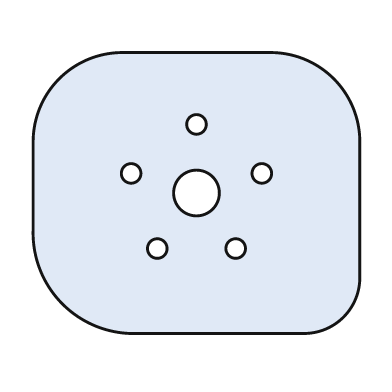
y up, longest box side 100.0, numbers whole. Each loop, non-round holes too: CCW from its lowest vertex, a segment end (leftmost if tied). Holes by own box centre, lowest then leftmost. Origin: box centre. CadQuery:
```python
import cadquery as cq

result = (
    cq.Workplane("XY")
    .moveTo(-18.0, -43.0)
    .lineTo(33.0, -43.0)
    .threePointArc((45.0, -38.0), (50.0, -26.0))
    .lineTo(50.0, 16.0)
    .threePointArc((42.0, 35.0), (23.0, 43.0))
    .lineTo(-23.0, 43.0)
    .threePointArc((-42.0, 35.0), (-50.0, 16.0))
    .lineTo(-50.0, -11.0)
    .threePointArc((-41.0, -34.0), (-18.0, -43.0))
    .close()
    .moveTo(-12.0, -17.0)
    .circle(3.0)
    .moveTo(12.0, -17.0)
    .circle(3.0)
    .moveTo(0.0, 0.0)
    .circle(7.0)
    .moveTo(-20.0, 6.0)
    .circle(3.0)
    .moveTo(20.0, 6.0)
    .circle(3.0)
    .moveTo(0.0, 21.0)
    .circle(3.0)
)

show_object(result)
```